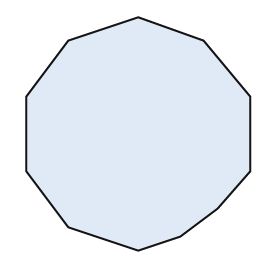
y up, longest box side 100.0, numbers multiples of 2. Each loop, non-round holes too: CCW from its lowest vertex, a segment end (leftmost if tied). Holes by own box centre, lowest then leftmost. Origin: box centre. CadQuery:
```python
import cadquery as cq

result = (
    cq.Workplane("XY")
    .moveTo(0.0, -50.0)
    .lineTo(18.0, -44.0)
    .lineTo(34.0, -32.0)
    .lineTo(48.0, -16.0)
    .lineTo(48.0, 16.0)
    .lineTo(28.0, 40.0)
    .lineTo(0.0, 50.0)
    .lineTo(-30.0, 40.0)
    .lineTo(-48.0, 16.0)
    .lineTo(-48.0, -16.0)
    .lineTo(-30.0, -40.0)
    .close()
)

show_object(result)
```